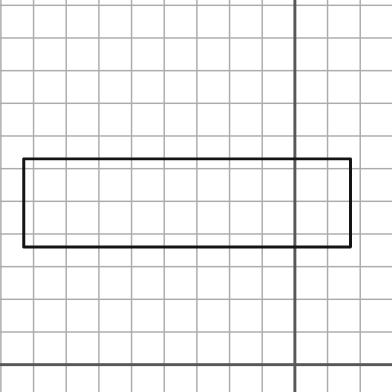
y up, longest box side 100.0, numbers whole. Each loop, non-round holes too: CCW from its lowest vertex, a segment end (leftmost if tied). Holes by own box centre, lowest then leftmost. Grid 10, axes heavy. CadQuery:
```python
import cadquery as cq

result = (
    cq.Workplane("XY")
    .moveTo(-83.0, 36.0)
    .lineTo(17.0, 36.0)
    .lineTo(17.0, 63.0)
    .lineTo(-83.0, 63.0)
    .close()
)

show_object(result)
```